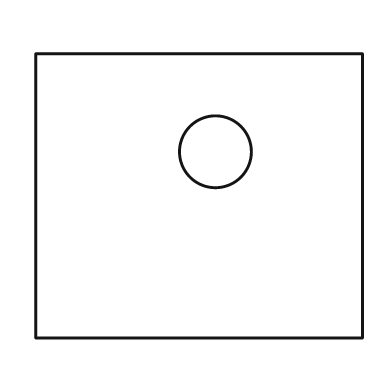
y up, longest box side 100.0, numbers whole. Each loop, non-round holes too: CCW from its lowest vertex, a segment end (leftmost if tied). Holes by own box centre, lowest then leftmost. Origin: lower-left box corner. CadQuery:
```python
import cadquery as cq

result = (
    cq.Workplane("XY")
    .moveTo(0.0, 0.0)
    .lineTo(100.0, 0.0)
    .lineTo(100.0, 87.0)
    .lineTo(0.0, 87.0)
    .close()
    .moveTo(55.0, 57.0)
    .circle(11.0)
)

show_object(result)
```